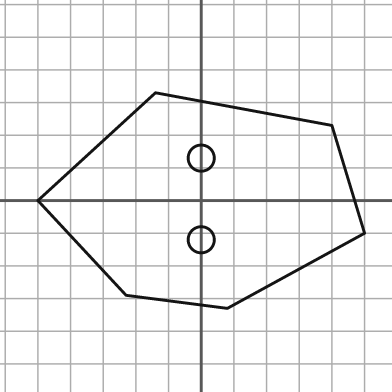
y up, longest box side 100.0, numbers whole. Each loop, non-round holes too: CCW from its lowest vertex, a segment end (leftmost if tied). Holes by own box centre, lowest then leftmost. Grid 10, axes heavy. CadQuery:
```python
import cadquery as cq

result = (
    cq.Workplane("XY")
    .moveTo(8.0, -33.0)
    .lineTo(50.0, -10.0)
    .lineTo(40.0, 23.0)
    .lineTo(-14.0, 33.0)
    .lineTo(-50.0, 0.0)
    .lineTo(-23.0, -29.0)
    .close()
    .moveTo(0.0, -12.0)
    .circle(4.0)
    .moveTo(0.0, 13.0)
    .circle(4.0)
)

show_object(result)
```